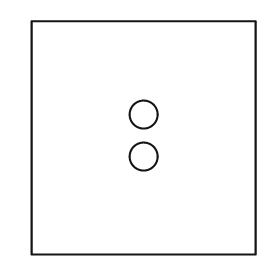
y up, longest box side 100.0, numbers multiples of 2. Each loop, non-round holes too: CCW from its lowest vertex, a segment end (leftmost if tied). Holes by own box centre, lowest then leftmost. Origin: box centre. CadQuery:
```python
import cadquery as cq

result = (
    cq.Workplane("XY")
    .moveTo(-48.0, -50.0)
    .lineTo(48.0, -50.0)
    .lineTo(48.0, 50.0)
    .lineTo(-48.0, 50.0)
    .close()
    .moveTo(0.0, -8.0)
    .circle(6.0)
    .moveTo(0.0, 10.0)
    .circle(6.0)
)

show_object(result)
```